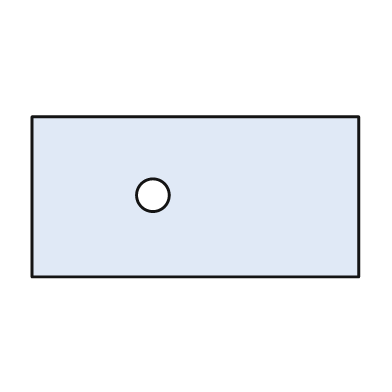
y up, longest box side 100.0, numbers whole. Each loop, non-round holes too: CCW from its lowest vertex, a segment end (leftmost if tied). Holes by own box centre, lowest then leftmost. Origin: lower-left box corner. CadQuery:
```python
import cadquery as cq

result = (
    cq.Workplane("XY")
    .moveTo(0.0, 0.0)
    .lineTo(100.0, 0.0)
    .lineTo(100.0, 49.0)
    .lineTo(0.0, 49.0)
    .close()
    .moveTo(37.0, 25.0)
    .circle(5.0)
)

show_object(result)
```